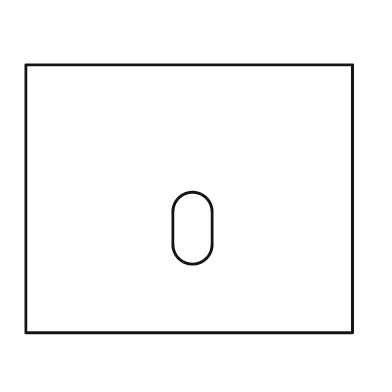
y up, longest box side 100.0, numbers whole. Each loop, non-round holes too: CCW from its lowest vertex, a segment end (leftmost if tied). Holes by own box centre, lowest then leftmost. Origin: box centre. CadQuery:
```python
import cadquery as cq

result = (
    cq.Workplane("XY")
    .moveTo(-50.0, -41.0)
    .lineTo(50.0, -41.0)
    .lineTo(50.0, 41.0)
    .lineTo(-50.0, 41.0)
    .close()
    .moveTo(-5.0, -14.0)
    .threePointArc((1.0, -20.0), (7.0, -14.0))
    .lineTo(7.0, -4.0)
    .threePointArc((1.0, 2.0), (-5.0, -4.0))
    .close()
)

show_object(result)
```